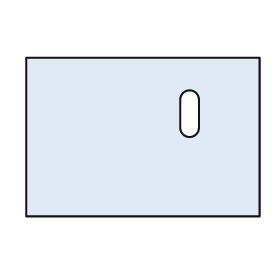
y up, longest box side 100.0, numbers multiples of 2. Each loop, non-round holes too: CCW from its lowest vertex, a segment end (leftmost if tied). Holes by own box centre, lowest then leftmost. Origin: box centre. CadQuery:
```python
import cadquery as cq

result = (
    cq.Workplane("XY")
    .moveTo(-50.0, -34.0)
    .lineTo(50.0, -34.0)
    .lineTo(50.0, 34.0)
    .lineTo(-50.0, 34.0)
    .close()
    .moveTo(16.0, 4.0)
    .threePointArc((20.0, 0.0), (24.0, 4.0))
    .lineTo(24.0, 16.0)
    .threePointArc((20.0, 20.0), (16.0, 16.0))
    .close()
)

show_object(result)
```